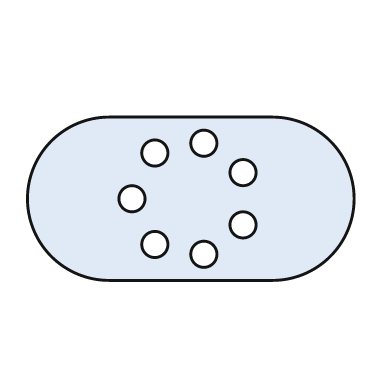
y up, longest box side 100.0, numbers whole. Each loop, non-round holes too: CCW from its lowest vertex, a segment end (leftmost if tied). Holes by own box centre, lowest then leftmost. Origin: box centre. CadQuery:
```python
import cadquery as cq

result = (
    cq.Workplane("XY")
    .moveTo(-25.0, -25.0)
    .lineTo(25.0, -25.0)
    .threePointArc((50.0, 0.0), (25.0, 25.0))
    .lineTo(-25.0, 25.0)
    .threePointArc((-50.0, 0.0), (-25.0, -25.0))
    .close()
    .moveTo(4.0, -17.0)
    .circle(4.0)
    .moveTo(-11.0, -14.0)
    .circle(4.0)
    .moveTo(16.0, -8.0)
    .circle(4.0)
    .moveTo(-18.0, 0.0)
    .circle(4.0)
    .moveTo(16.0, 8.0)
    .circle(4.0)
    .moveTo(-11.0, 14.0)
    .circle(4.0)
    .moveTo(4.0, 17.0)
    .circle(4.0)
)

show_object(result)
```